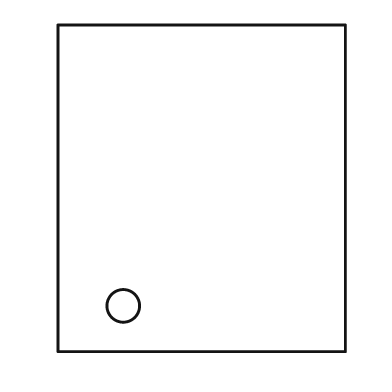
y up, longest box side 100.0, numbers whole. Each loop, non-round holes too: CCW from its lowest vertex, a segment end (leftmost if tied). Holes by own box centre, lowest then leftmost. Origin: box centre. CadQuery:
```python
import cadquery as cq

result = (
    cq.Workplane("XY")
    .moveTo(-44.0, -50.0)
    .lineTo(44.0, -50.0)
    .lineTo(44.0, 50.0)
    .lineTo(-44.0, 50.0)
    .close()
    .moveTo(-24.0, -36.0)
    .circle(5.0)
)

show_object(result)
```